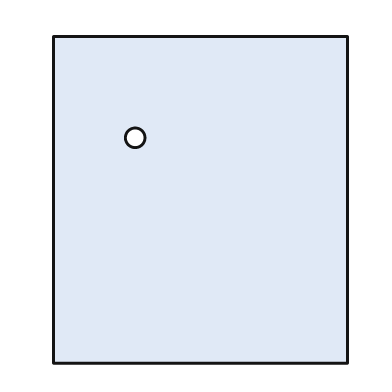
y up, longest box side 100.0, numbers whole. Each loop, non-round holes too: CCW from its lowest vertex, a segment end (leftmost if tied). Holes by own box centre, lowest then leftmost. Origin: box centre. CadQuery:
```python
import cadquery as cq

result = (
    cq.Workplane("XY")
    .moveTo(-45.0, -50.0)
    .lineTo(45.0, -50.0)
    .lineTo(45.0, 50.0)
    .lineTo(-45.0, 50.0)
    .close()
    .moveTo(-20.0, 19.0)
    .circle(3.0)
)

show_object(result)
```